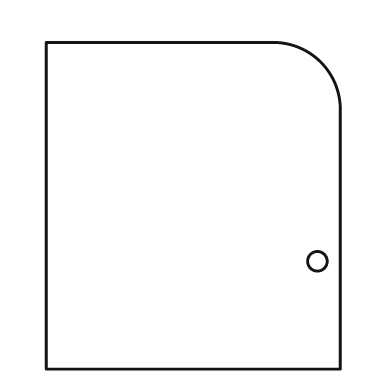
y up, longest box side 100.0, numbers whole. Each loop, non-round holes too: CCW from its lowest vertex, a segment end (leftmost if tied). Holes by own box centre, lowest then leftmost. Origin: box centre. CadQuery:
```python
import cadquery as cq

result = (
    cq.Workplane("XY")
    .moveTo(-45.0, -50.0)
    .lineTo(45.0, -50.0)
    .lineTo(45.0, 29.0)
    .threePointArc((39.0, 44.0), (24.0, 50.0))
    .lineTo(-45.0, 50.0)
    .close()
    .moveTo(38.0, -17.0)
    .circle(3.0)
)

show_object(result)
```